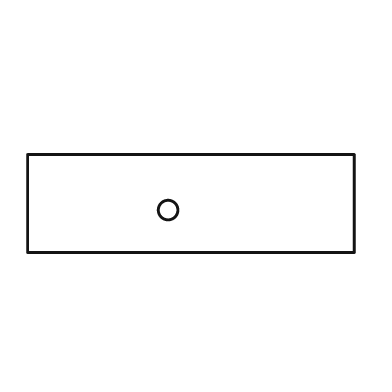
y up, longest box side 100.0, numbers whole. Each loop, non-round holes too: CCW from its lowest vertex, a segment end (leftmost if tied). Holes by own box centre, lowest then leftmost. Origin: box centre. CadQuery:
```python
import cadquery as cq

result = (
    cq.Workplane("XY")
    .moveTo(-50.0, -15.0)
    .lineTo(50.0, -15.0)
    .lineTo(50.0, 15.0)
    .lineTo(-50.0, 15.0)
    .close()
    .moveTo(-7.0, -2.0)
    .circle(3.0)
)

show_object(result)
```